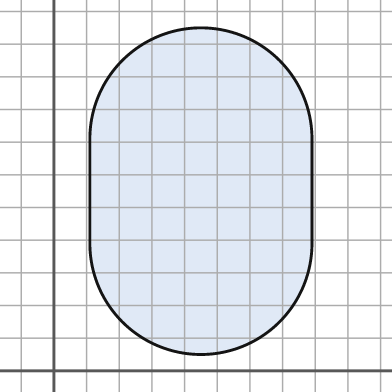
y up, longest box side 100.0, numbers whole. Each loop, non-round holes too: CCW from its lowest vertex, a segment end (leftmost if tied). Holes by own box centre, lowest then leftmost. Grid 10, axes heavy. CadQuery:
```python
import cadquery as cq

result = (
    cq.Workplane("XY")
    .moveTo(11.0, 39.0)
    .threePointArc((45.0, 5.0), (79.0, 39.0))
    .lineTo(79.0, 71.0)
    .threePointArc((45.0, 105.0), (11.0, 71.0))
    .close()
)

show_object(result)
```